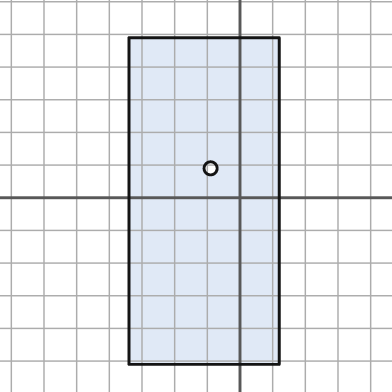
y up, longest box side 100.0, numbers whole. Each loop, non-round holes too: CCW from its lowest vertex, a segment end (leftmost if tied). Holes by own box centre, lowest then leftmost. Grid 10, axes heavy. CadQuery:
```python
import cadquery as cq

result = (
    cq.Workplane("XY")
    .moveTo(-34.0, -51.0)
    .lineTo(12.0, -51.0)
    .lineTo(12.0, 49.0)
    .lineTo(-34.0, 49.0)
    .close()
    .moveTo(-9.0, 9.0)
    .circle(2.0)
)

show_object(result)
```